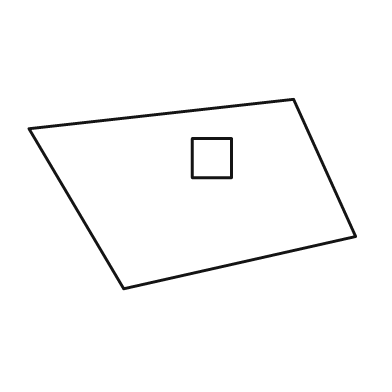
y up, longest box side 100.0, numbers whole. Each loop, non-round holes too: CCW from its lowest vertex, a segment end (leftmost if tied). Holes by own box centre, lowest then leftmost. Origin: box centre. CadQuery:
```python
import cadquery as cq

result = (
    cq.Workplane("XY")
    .moveTo(-21.0, -29.0)
    .lineTo(50.0, -13.0)
    .lineTo(31.0, 29.0)
    .lineTo(-50.0, 20.0)
    .close()
    .moveTo(0.0, 5.0)
    .lineTo(12.0, 5.0)
    .lineTo(12.0, 17.0)
    .lineTo(0.0, 17.0)
    .close()
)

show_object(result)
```